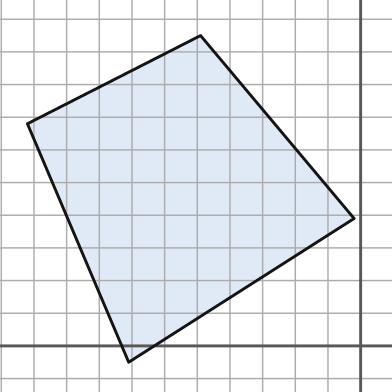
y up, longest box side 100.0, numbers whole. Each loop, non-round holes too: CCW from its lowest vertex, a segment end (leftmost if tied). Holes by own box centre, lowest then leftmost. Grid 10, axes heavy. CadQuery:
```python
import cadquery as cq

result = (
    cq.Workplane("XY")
    .moveTo(-71.0, -5.0)
    .lineTo(-2.0, 39.0)
    .lineTo(-49.0, 95.0)
    .lineTo(-102.0, 68.0)
    .close()
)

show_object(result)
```